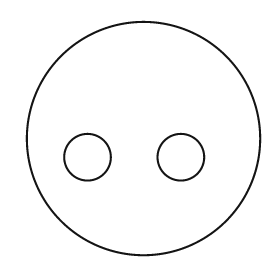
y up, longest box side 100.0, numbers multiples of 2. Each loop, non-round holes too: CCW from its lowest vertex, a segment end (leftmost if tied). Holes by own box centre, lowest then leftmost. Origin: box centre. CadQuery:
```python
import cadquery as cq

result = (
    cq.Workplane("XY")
    .moveTo(0.0, 0.0)
    .circle(50.0)
    .moveTo(-24.0, -8.0)
    .circle(10.0)
    .moveTo(16.0, -8.0)
    .circle(10.0)
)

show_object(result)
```